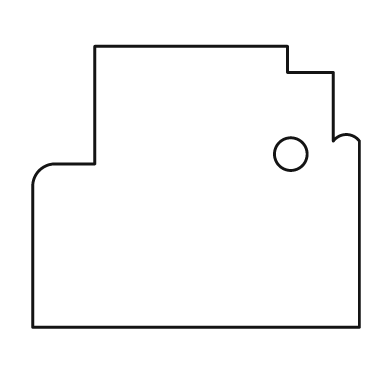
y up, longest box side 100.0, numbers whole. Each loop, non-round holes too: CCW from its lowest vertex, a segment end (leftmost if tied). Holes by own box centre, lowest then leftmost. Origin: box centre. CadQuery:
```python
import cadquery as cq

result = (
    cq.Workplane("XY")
    .moveTo(-50.0, -43.0)
    .lineTo(50.0, -43.0)
    .lineTo(50.0, 14.0)
    .threePointArc((46.0, 16.0), (42.0, 14.0))
    .lineTo(42.0, 35.0)
    .lineTo(28.0, 35.0)
    .lineTo(28.0, 43.0)
    .lineTo(-31.0, 43.0)
    .lineTo(-31.0, 7.0)
    .lineTo(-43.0, 7.0)
    .threePointArc((-48.0, 5.0), (-50.0, 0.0))
    .close()
    .moveTo(29.0, 10.0)
    .circle(5.0)
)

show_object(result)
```